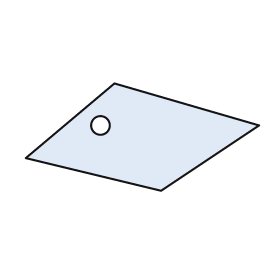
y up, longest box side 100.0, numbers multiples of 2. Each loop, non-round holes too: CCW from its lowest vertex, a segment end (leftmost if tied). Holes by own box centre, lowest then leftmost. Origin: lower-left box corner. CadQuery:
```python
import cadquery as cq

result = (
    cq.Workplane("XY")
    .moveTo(58.0, 0.0)
    .lineTo(100.0, 28.0)
    .lineTo(38.0, 46.0)
    .lineTo(0.0, 14.0)
    .close()
    .moveTo(32.0, 28.0)
    .circle(4.0)
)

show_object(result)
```